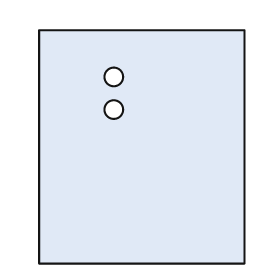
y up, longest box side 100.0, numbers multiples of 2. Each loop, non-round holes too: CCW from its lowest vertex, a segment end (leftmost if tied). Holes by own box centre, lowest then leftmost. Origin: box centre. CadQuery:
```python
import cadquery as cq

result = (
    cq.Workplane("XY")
    .moveTo(-44.0, -50.0)
    .lineTo(44.0, -50.0)
    .lineTo(44.0, 50.0)
    .lineTo(-44.0, 50.0)
    .close()
    .moveTo(-12.0, 16.0)
    .circle(4.0)
    .moveTo(-12.0, 30.0)
    .circle(4.0)
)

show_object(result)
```